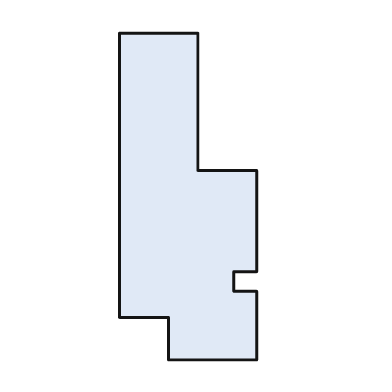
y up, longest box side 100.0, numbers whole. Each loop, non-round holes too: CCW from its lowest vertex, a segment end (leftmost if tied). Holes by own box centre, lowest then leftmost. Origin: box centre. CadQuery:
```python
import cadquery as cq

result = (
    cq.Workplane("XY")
    .moveTo(-6.0, -50.0)
    .lineTo(21.0, -50.0)
    .lineTo(21.0, -29.0)
    .lineTo(14.0, -29.0)
    .lineTo(14.0, -23.0)
    .lineTo(21.0, -23.0)
    .lineTo(21.0, 8.0)
    .lineTo(3.0, 8.0)
    .lineTo(3.0, 50.0)
    .lineTo(-21.0, 50.0)
    .lineTo(-21.0, -37.0)
    .lineTo(-6.0, -37.0)
    .close()
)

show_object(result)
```